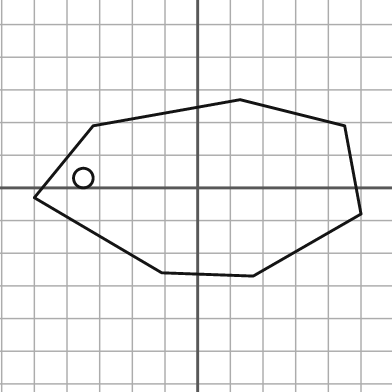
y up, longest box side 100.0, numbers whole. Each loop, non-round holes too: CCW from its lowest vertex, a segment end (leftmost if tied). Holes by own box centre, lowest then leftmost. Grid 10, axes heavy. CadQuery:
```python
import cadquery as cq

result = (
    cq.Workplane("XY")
    .moveTo(17.0, -27.0)
    .lineTo(50.0, -8.0)
    .lineTo(45.0, 19.0)
    .lineTo(13.0, 27.0)
    .lineTo(-32.0, 19.0)
    .lineTo(-50.0, -3.0)
    .lineTo(-11.0, -26.0)
    .close()
    .moveTo(-35.0, 3.0)
    .circle(3.0)
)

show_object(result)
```